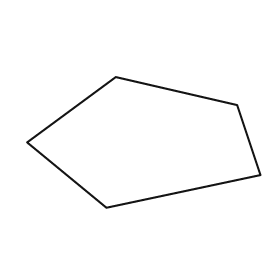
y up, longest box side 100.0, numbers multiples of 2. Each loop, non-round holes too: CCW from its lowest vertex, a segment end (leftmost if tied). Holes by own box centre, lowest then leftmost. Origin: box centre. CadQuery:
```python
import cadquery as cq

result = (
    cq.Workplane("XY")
    .moveTo(-16.0, -28.0)
    .lineTo(50.0, -14.0)
    .lineTo(40.0, 16.0)
    .lineTo(-12.0, 28.0)
    .lineTo(-50.0, 0.0)
    .close()
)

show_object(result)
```